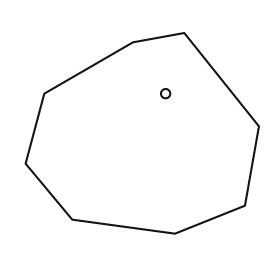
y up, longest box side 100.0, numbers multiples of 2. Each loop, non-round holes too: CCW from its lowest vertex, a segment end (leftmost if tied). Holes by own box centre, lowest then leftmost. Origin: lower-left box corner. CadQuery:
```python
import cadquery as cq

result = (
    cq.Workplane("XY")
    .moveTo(64.0, 0.0)
    .lineTo(94.0, 12.0)
    .lineTo(100.0, 46.0)
    .lineTo(68.0, 86.0)
    .lineTo(46.0, 82.0)
    .lineTo(8.0, 60.0)
    .lineTo(0.0, 30.0)
    .lineTo(20.0, 6.0)
    .close()
    .moveTo(60.0, 60.0)
    .circle(2.0)
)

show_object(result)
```